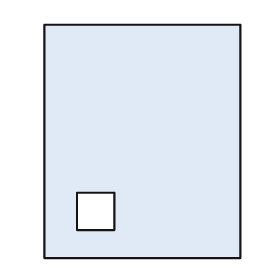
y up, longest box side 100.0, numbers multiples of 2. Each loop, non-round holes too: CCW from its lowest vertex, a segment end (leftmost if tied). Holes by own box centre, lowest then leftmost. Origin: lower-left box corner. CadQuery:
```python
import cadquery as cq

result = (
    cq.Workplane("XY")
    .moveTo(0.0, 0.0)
    .lineTo(84.0, 0.0)
    .lineTo(84.0, 100.0)
    .lineTo(0.0, 100.0)
    .close()
    .moveTo(14.0, 12.0)
    .lineTo(30.0, 12.0)
    .lineTo(30.0, 28.0)
    .lineTo(14.0, 28.0)
    .close()
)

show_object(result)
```